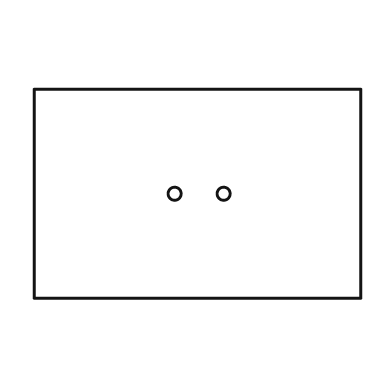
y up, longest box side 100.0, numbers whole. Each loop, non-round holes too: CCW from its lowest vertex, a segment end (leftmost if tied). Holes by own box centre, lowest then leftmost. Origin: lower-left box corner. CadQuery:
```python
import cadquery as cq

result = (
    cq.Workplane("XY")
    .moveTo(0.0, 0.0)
    .lineTo(100.0, 0.0)
    .lineTo(100.0, 64.0)
    .lineTo(0.0, 64.0)
    .close()
    .moveTo(43.0, 32.0)
    .circle(2.0)
    .moveTo(58.0, 32.0)
    .circle(2.0)
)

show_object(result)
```